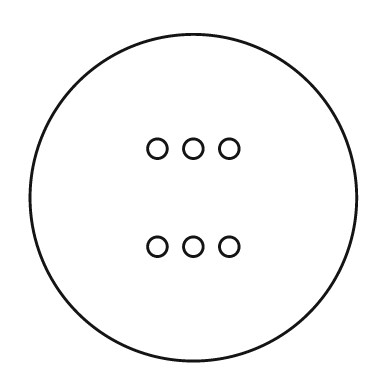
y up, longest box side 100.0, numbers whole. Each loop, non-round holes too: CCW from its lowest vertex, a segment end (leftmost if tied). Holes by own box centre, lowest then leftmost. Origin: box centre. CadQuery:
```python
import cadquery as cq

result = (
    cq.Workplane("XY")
    .moveTo(0.0, 0.0)
    .circle(50.0)
    .moveTo(-11.0, -15.0)
    .circle(3.0)
    .moveTo(0.0, -15.0)
    .circle(3.0)
    .moveTo(11.0, -15.0)
    .circle(3.0)
    .moveTo(-11.0, 15.0)
    .circle(3.0)
    .moveTo(0.0, 15.0)
    .circle(3.0)
    .moveTo(11.0, 15.0)
    .circle(3.0)
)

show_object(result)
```